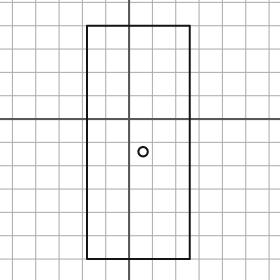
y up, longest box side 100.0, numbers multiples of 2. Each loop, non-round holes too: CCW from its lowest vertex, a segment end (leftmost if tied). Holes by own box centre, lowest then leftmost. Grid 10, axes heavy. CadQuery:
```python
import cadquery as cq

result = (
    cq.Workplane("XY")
    .moveTo(-18.0, -60.0)
    .lineTo(26.0, -60.0)
    .lineTo(26.0, 40.0)
    .lineTo(-18.0, 40.0)
    .close()
    .moveTo(6.0, -14.0)
    .circle(2.0)
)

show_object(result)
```